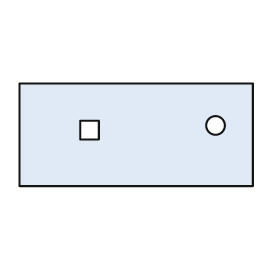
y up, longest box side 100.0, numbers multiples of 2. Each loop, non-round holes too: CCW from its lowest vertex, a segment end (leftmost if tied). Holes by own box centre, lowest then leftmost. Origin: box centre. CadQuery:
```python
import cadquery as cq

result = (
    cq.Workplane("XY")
    .moveTo(-50.0, -22.0)
    .lineTo(50.0, -22.0)
    .lineTo(50.0, 22.0)
    .lineTo(-50.0, 22.0)
    .close()
    .moveTo(-24.0, -2.0)
    .lineTo(-16.0, -2.0)
    .lineTo(-16.0, 6.0)
    .lineTo(-24.0, 6.0)
    .close()
    .moveTo(34.0, 4.0)
    .circle(4.0)
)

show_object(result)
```